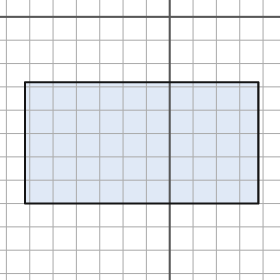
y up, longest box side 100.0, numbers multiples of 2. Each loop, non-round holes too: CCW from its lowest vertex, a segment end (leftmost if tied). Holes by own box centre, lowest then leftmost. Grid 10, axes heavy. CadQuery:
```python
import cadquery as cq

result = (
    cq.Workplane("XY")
    .moveTo(-62.0, -80.0)
    .lineTo(38.0, -80.0)
    .lineTo(38.0, -28.0)
    .lineTo(-62.0, -28.0)
    .close()
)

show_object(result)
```